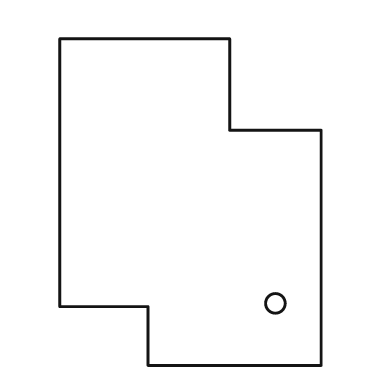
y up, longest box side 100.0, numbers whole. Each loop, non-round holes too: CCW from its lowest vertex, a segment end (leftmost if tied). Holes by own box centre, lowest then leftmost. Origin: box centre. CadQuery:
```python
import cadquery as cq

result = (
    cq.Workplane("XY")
    .moveTo(-13.0, -50.0)
    .lineTo(40.0, -50.0)
    .lineTo(40.0, 22.0)
    .lineTo(12.0, 22.0)
    .lineTo(12.0, 50.0)
    .lineTo(-40.0, 50.0)
    .lineTo(-40.0, -32.0)
    .lineTo(-13.0, -32.0)
    .close()
    .moveTo(26.0, -31.0)
    .circle(3.0)
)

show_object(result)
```